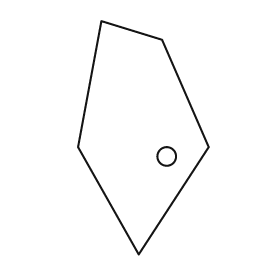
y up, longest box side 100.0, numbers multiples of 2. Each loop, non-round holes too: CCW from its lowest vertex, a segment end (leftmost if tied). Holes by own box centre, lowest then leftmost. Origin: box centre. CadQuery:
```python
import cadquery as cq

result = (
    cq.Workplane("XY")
    .moveTo(-2.0, -50.0)
    .lineTo(28.0, -4.0)
    .lineTo(8.0, 42.0)
    .lineTo(-18.0, 50.0)
    .lineTo(-28.0, -4.0)
    .close()
    .moveTo(10.0, -8.0)
    .circle(4.0)
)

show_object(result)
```